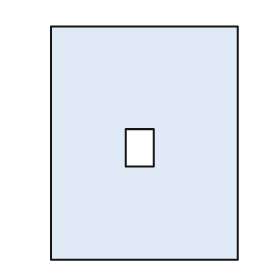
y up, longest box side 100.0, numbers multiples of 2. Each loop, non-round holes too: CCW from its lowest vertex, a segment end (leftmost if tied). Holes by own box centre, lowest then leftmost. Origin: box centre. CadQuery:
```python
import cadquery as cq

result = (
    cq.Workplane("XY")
    .moveTo(-40.0, -50.0)
    .lineTo(40.0, -50.0)
    .lineTo(40.0, 50.0)
    .lineTo(-40.0, 50.0)
    .close()
    .moveTo(-8.0, -10.0)
    .lineTo(4.0, -10.0)
    .lineTo(4.0, 6.0)
    .lineTo(-8.0, 6.0)
    .close()
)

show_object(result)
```